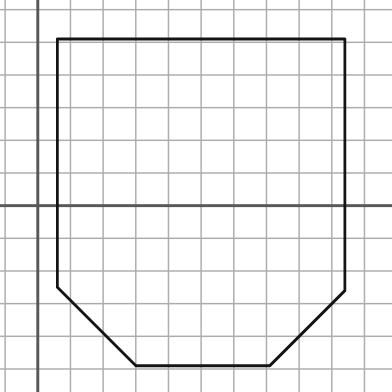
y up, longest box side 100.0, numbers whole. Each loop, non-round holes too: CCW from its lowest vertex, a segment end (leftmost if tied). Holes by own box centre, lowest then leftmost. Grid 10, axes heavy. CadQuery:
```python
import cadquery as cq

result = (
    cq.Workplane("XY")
    .moveTo(30.0, -49.0)
    .lineTo(71.0, -49.0)
    .lineTo(94.0, -26.0)
    .lineTo(94.0, 51.0)
    .lineTo(6.0, 51.0)
    .lineTo(6.0, -25.0)
    .close()
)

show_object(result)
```